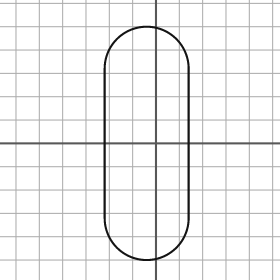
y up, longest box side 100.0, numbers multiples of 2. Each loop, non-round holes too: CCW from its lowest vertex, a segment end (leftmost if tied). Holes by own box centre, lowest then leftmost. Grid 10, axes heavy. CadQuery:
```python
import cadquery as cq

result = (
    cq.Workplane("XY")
    .moveTo(-22.0, -32.0)
    .threePointArc((-4.0, -50.0), (14.0, -32.0))
    .lineTo(14.0, 32.0)
    .threePointArc((-4.0, 50.0), (-22.0, 32.0))
    .close()
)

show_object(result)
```